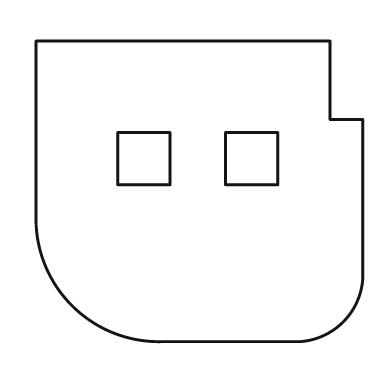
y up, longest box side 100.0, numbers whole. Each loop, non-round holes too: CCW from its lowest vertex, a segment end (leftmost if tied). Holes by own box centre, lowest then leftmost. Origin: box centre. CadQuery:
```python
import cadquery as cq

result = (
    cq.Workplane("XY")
    .moveTo(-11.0, -46.0)
    .lineTo(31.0, -46.0)
    .threePointArc((44.0, -40.0), (50.0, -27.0))
    .lineTo(50.0, 22.0)
    .lineTo(40.0, 22.0)
    .lineTo(40.0, 46.0)
    .lineTo(-50.0, 46.0)
    .lineTo(-50.0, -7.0)
    .threePointArc((-39.0, -35.0), (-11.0, -46.0))
    .close()
    .moveTo(-25.0, 2.0)
    .lineTo(-9.0, 2.0)
    .lineTo(-9.0, 18.0)
    .lineTo(-25.0, 18.0)
    .close()
    .moveTo(8.0, 2.0)
    .lineTo(24.0, 2.0)
    .lineTo(24.0, 18.0)
    .lineTo(8.0, 18.0)
    .close()
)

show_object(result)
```